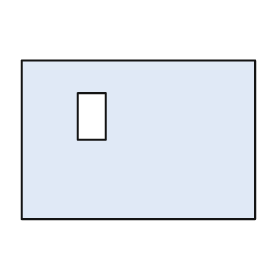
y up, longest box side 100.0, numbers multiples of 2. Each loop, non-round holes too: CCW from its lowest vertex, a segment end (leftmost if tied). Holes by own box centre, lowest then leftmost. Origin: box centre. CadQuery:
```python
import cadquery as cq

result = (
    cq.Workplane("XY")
    .moveTo(-50.0, -34.0)
    .lineTo(50.0, -34.0)
    .lineTo(50.0, 34.0)
    .lineTo(-50.0, 34.0)
    .close()
    .moveTo(-26.0, 0.0)
    .lineTo(-14.0, 0.0)
    .lineTo(-14.0, 20.0)
    .lineTo(-26.0, 20.0)
    .close()
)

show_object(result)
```